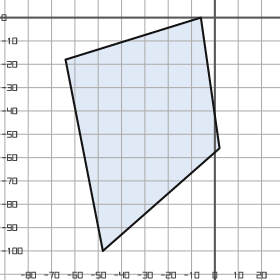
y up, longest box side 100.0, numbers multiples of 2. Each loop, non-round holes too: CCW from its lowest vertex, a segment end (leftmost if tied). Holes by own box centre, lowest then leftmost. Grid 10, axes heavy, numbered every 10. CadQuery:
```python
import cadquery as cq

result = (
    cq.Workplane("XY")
    .moveTo(-48.0, -100.0)
    .lineTo(2.0, -56.0)
    .lineTo(-6.0, 0.0)
    .lineTo(-64.0, -18.0)
    .close()
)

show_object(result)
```